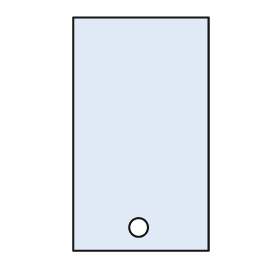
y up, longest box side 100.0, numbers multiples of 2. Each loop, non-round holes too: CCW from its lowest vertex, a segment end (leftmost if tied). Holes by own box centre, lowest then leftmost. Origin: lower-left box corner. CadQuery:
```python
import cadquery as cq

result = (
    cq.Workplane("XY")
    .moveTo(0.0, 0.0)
    .lineTo(58.0, 0.0)
    .lineTo(58.0, 100.0)
    .lineTo(0.0, 100.0)
    .close()
    .moveTo(28.0, 10.0)
    .circle(4.0)
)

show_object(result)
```